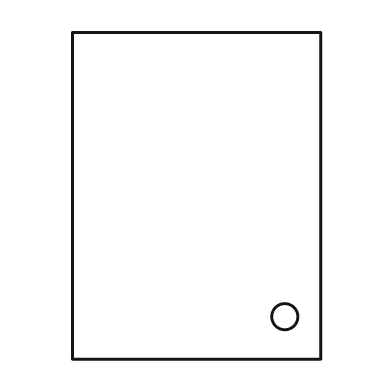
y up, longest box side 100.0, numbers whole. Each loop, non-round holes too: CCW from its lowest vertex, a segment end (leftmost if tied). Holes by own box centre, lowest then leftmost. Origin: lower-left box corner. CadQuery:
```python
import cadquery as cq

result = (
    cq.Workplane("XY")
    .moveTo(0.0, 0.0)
    .lineTo(76.0, 0.0)
    .lineTo(76.0, 100.0)
    .lineTo(0.0, 100.0)
    .close()
    .moveTo(65.0, 13.0)
    .circle(4.0)
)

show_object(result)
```